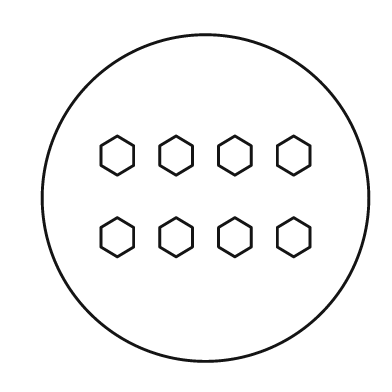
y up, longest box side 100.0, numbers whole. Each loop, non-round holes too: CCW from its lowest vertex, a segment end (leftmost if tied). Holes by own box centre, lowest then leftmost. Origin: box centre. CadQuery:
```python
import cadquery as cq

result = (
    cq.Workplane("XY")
    .moveTo(0.0, 0.0)
    .circle(50.0)
    .moveTo(-27.0, -18.0)
    .lineTo(-22.0, -15.0)
    .lineTo(-22.0, -9.0)
    .lineTo(-27.0, -6.0)
    .lineTo(-32.0, -9.0)
    .lineTo(-32.0, -15.0)
    .close()
    .moveTo(-9.0, -18.0)
    .lineTo(-4.0, -15.0)
    .lineTo(-4.0, -9.0)
    .lineTo(-9.0, -6.0)
    .lineTo(-14.0, -9.0)
    .lineTo(-14.0, -15.0)
    .close()
    .moveTo(9.0, -18.0)
    .lineTo(14.0, -15.0)
    .lineTo(14.0, -9.0)
    .lineTo(9.0, -6.0)
    .lineTo(4.0, -9.0)
    .lineTo(4.0, -15.0)
    .close()
    .moveTo(27.0, -18.0)
    .lineTo(32.0, -15.0)
    .lineTo(32.0, -9.0)
    .lineTo(27.0, -6.0)
    .lineTo(22.0, -9.0)
    .lineTo(22.0, -15.0)
    .close()
    .moveTo(-27.0, 7.0)
    .lineTo(-22.0, 10.0)
    .lineTo(-22.0, 16.0)
    .lineTo(-27.0, 19.0)
    .lineTo(-32.0, 16.0)
    .lineTo(-32.0, 10.0)
    .close()
    .moveTo(-9.0, 7.0)
    .lineTo(-4.0, 10.0)
    .lineTo(-4.0, 16.0)
    .lineTo(-9.0, 19.0)
    .lineTo(-14.0, 16.0)
    .lineTo(-14.0, 10.0)
    .close()
    .moveTo(9.0, 7.0)
    .lineTo(14.0, 10.0)
    .lineTo(14.0, 16.0)
    .lineTo(9.0, 19.0)
    .lineTo(4.0, 16.0)
    .lineTo(4.0, 10.0)
    .close()
    .moveTo(27.0, 7.0)
    .lineTo(32.0, 10.0)
    .lineTo(32.0, 16.0)
    .lineTo(27.0, 19.0)
    .lineTo(22.0, 16.0)
    .lineTo(22.0, 10.0)
    .close()
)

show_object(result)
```